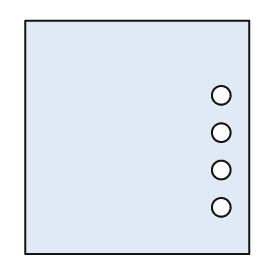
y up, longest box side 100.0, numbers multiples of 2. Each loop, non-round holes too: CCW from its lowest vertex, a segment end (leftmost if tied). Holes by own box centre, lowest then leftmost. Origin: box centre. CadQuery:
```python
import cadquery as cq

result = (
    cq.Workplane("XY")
    .moveTo(-48.0, -50.0)
    .lineTo(48.0, -50.0)
    .lineTo(48.0, 50.0)
    .lineTo(-48.0, 50.0)
    .close()
    .moveTo(36.0, -30.0)
    .circle(4.0)
    .moveTo(36.0, -14.0)
    .circle(4.0)
    .moveTo(36.0, 2.0)
    .circle(4.0)
    .moveTo(36.0, 18.0)
    .circle(4.0)
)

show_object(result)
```